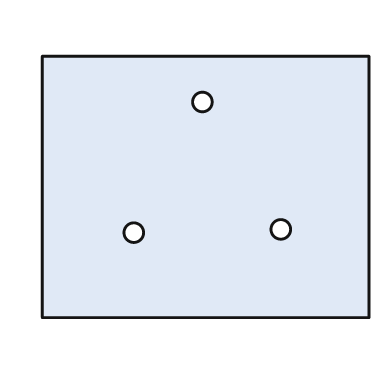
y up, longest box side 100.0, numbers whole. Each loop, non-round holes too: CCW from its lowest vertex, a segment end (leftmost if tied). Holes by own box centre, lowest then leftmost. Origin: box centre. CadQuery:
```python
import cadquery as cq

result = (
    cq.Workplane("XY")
    .moveTo(-50.0, -40.0)
    .lineTo(50.0, -40.0)
    .lineTo(50.0, 40.0)
    .lineTo(-50.0, 40.0)
    .close()
    .moveTo(-22.0, -14.0)
    .circle(3.0)
    .moveTo(23.0, -13.0)
    .circle(3.0)
    .moveTo(-1.0, 26.0)
    .circle(3.0)
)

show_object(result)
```